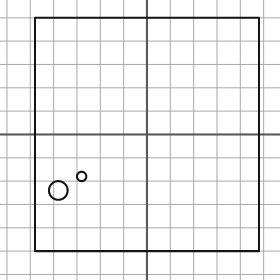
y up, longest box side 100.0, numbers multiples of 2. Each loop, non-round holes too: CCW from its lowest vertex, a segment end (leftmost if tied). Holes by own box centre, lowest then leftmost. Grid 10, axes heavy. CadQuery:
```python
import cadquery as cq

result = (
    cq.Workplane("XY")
    .moveTo(-48.0, -50.0)
    .lineTo(48.0, -50.0)
    .lineTo(48.0, 50.0)
    .lineTo(-48.0, 50.0)
    .close()
    .moveTo(-38.0, -24.0)
    .circle(4.0)
    .moveTo(-28.0, -18.0)
    .circle(2.0)
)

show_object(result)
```